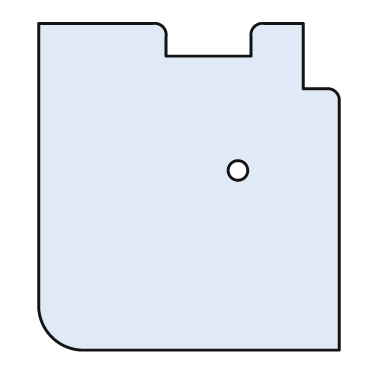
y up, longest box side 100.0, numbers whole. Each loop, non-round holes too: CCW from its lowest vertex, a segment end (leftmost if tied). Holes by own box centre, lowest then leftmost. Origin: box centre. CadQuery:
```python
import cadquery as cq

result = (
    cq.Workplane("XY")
    .moveTo(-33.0, -50.0)
    .lineTo(46.0, -50.0)
    .lineTo(46.0, 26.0)
    .threePointArc((45.0, 29.0), (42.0, 30.0))
    .lineTo(35.0, 30.0)
    .lineTo(35.0, 50.0)
    .lineTo(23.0, 50.0)
    .threePointArc((20.0, 49.0), (19.0, 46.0))
    .lineTo(19.0, 40.0)
    .lineTo(-7.0, 40.0)
    .lineTo(-7.0, 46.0)
    .threePointArc((-8.0, 49.0), (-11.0, 50.0))
    .lineTo(-46.0, 50.0)
    .lineTo(-46.0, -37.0)
    .threePointArc((-42.0, -46.0), (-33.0, -50.0))
    .close()
    .moveTo(15.0, 5.0)
    .circle(3.0)
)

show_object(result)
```